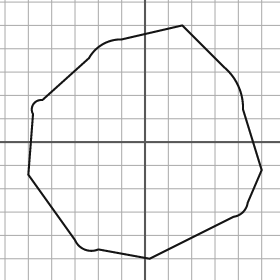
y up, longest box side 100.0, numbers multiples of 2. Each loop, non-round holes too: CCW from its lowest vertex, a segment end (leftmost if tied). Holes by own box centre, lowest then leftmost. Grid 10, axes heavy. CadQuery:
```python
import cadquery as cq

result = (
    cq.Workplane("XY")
    .moveTo(2.0, -50.0)
    .lineTo(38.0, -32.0)
    .threePointArc((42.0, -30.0), (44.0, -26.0))
    .lineTo(50.0, -12.0)
    .lineTo(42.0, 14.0)
    .threePointArc((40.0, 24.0), (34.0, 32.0))
    .lineTo(16.0, 50.0)
    .lineTo(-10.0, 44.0)
    .threePointArc((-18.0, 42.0), (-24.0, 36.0))
    .lineTo(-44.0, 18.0)
    .threePointArc((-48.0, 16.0), (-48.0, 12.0))
    .lineTo(-50.0, -14.0)
    .lineTo(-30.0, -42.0)
    .threePointArc((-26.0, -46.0), (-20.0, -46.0))
    .close()
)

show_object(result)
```